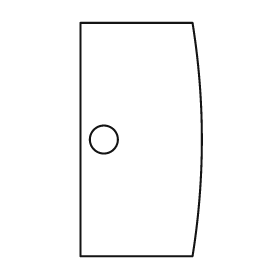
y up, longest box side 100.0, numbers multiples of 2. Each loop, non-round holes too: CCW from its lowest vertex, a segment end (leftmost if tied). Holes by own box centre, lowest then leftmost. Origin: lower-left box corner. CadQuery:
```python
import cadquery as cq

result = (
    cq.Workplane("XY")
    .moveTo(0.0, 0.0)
    .lineTo(48.0, 0.0)
    .threePointArc((52.0, 50.0), (48.0, 100.0))
    .lineTo(0.0, 100.0)
    .close()
    .moveTo(10.0, 50.0)
    .circle(6.0)
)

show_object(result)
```